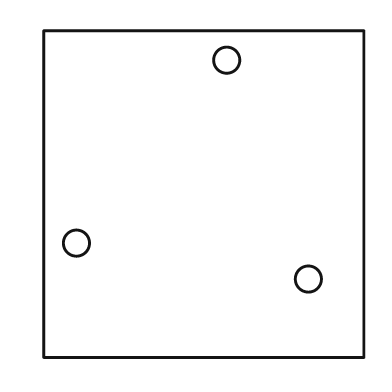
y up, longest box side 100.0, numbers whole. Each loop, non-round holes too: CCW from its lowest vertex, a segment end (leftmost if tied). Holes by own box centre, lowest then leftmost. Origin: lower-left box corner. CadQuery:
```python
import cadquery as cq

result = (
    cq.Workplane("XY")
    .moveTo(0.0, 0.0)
    .lineTo(98.0, 0.0)
    .lineTo(98.0, 100.0)
    .lineTo(0.0, 100.0)
    .close()
    .moveTo(81.0, 24.0)
    .circle(4.0)
    .moveTo(10.0, 35.0)
    .circle(4.0)
    .moveTo(56.0, 91.0)
    .circle(4.0)
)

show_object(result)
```